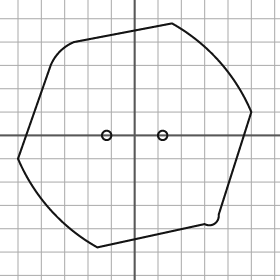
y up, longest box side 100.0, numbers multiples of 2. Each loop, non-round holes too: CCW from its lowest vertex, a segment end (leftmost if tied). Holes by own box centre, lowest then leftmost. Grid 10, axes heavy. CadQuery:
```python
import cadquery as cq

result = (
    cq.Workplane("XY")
    .moveTo(-16.0, -48.0)
    .lineTo(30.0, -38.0)
    .threePointArc((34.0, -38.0), (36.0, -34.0))
    .lineTo(50.0, 10.0)
    .threePointArc((36.0, 32.0), (16.0, 48.0))
    .lineTo(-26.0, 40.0)
    .threePointArc((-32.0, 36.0), (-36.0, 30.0))
    .lineTo(-50.0, -10.0)
    .threePointArc((-36.0, -32.0), (-16.0, -48.0))
    .close()
    .moveTo(-12.0, 0.0)
    .circle(2.0)
    .moveTo(12.0, 0.0)
    .circle(2.0)
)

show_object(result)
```